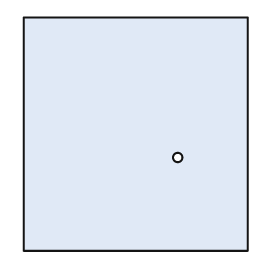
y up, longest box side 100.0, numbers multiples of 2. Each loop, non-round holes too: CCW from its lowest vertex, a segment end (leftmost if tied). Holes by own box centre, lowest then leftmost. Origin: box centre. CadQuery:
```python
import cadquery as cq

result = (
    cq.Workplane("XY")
    .moveTo(-48.0, -50.0)
    .lineTo(48.0, -50.0)
    .lineTo(48.0, 50.0)
    .lineTo(-48.0, 50.0)
    .close()
    .moveTo(18.0, -10.0)
    .circle(2.0)
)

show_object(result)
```